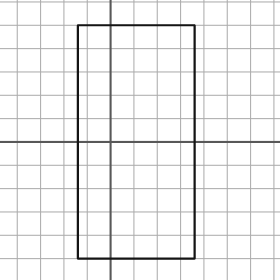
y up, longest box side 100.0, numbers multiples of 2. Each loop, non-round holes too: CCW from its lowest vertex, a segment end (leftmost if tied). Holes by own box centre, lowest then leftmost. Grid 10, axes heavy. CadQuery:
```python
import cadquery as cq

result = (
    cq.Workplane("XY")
    .moveTo(-14.0, -50.0)
    .lineTo(36.0, -50.0)
    .lineTo(36.0, 50.0)
    .lineTo(-14.0, 50.0)
    .close()
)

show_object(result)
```